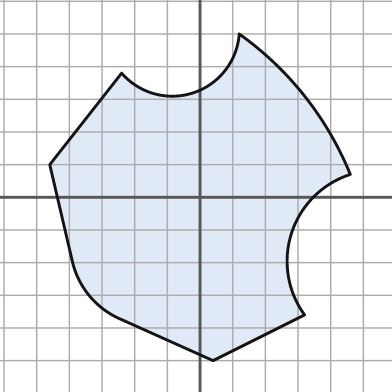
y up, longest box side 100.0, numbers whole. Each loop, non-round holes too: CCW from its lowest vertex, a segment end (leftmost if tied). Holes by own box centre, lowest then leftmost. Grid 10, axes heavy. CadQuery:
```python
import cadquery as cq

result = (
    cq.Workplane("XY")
    .moveTo(4.0, -50.0)
    .lineTo(32.0, -36.0)
    .threePointArc((28.0, -11.0), (46.0, 7.0))
    .threePointArc((32.0, 31.0), (12.0, 50.0))
    .threePointArc((-2.0, 32.0), (-24.0, 38.0))
    .lineTo(-46.0, 10.0)
    .lineTo(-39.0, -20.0)
    .threePointArc((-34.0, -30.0), (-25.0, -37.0))
    .close()
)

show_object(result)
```